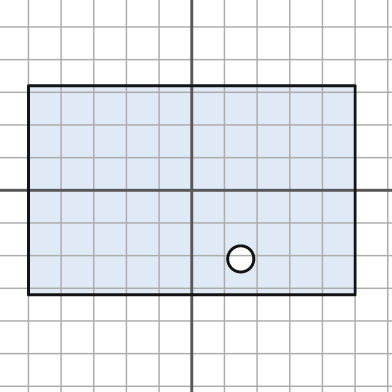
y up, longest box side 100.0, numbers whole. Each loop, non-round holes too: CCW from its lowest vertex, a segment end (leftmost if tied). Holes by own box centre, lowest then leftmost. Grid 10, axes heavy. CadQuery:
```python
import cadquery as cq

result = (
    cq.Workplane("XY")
    .moveTo(-50.0, -32.0)
    .lineTo(50.0, -32.0)
    .lineTo(50.0, 32.0)
    .lineTo(-50.0, 32.0)
    .close()
    .moveTo(15.0, -21.0)
    .circle(4.0)
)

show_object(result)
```